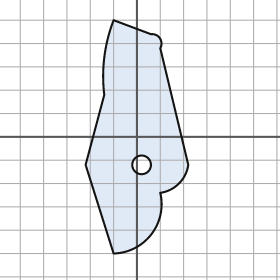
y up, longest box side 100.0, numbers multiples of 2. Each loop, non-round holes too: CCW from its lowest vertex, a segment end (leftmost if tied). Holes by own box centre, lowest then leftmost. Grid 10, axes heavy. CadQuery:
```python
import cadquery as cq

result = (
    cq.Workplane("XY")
    .moveTo(-10.0, -50.0)
    .threePointArc((6.0, -42.0), (10.0, -24.0))
    .threePointArc((18.0, -20.0), (22.0, -12.0))
    .lineTo(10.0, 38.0)
    .threePointArc((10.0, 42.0), (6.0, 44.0))
    .lineTo(-10.0, 50.0)
    .threePointArc((-14.0, 34.0), (-14.0, 18.0))
    .lineTo(-22.0, -12.0)
    .close()
    .moveTo(2.0, -12.0)
    .circle(4.0)
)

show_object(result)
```